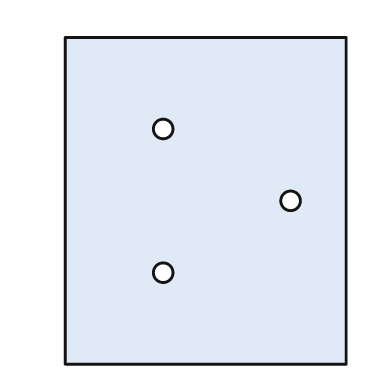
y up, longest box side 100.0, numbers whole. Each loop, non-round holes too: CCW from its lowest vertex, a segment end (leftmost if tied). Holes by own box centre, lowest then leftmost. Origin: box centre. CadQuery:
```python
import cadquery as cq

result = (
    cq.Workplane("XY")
    .moveTo(-43.0, -50.0)
    .lineTo(43.0, -50.0)
    .lineTo(43.0, 50.0)
    .lineTo(-43.0, 50.0)
    .close()
    .moveTo(-13.0, -22.0)
    .circle(3.0)
    .moveTo(26.0, 0.0)
    .circle(3.0)
    .moveTo(-13.0, 22.0)
    .circle(3.0)
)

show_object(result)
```